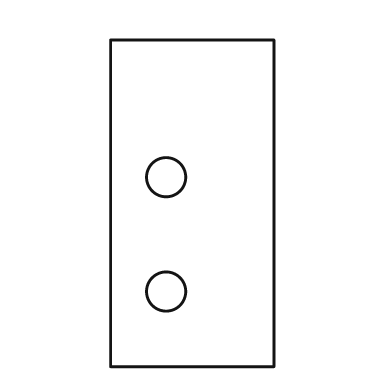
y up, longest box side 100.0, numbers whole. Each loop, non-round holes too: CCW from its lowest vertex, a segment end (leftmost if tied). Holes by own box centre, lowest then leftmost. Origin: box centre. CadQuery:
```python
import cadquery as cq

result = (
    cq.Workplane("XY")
    .moveTo(-25.0, -50.0)
    .lineTo(25.0, -50.0)
    .lineTo(25.0, 50.0)
    .lineTo(-25.0, 50.0)
    .close()
    .moveTo(-8.0, -27.0)
    .circle(6.0)
    .moveTo(-8.0, 8.0)
    .circle(6.0)
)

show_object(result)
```